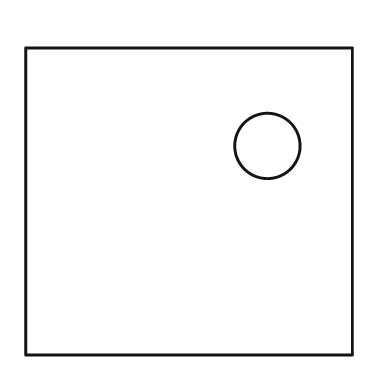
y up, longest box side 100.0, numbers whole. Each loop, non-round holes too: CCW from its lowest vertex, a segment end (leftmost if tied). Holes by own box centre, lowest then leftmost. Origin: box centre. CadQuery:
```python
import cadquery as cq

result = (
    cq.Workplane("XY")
    .moveTo(-50.0, -47.0)
    .lineTo(50.0, -47.0)
    .lineTo(50.0, 47.0)
    .lineTo(-50.0, 47.0)
    .close()
    .moveTo(24.0, 17.0)
    .circle(10.0)
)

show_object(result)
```